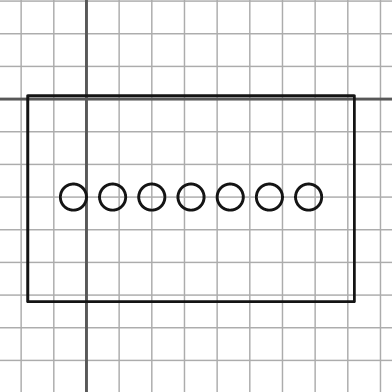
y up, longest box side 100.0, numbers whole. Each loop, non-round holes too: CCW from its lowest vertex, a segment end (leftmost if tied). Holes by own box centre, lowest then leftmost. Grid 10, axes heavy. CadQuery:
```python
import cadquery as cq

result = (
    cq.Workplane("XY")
    .moveTo(-18.0, -62.0)
    .lineTo(82.0, -62.0)
    .lineTo(82.0, 1.0)
    .lineTo(-18.0, 1.0)
    .close()
    .moveTo(-4.0, -30.0)
    .circle(4.0)
    .moveTo(8.0, -30.0)
    .circle(4.0)
    .moveTo(20.0, -30.0)
    .circle(4.0)
    .moveTo(32.0, -30.0)
    .circle(4.0)
    .moveTo(44.0, -30.0)
    .circle(4.0)
    .moveTo(56.0, -30.0)
    .circle(4.0)
    .moveTo(68.0, -30.0)
    .circle(4.0)
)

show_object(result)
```